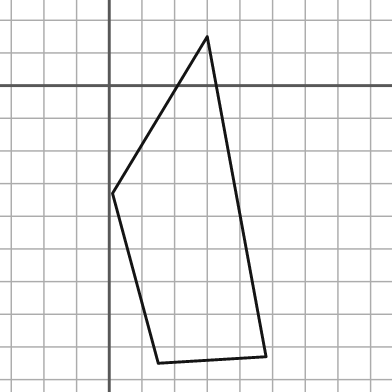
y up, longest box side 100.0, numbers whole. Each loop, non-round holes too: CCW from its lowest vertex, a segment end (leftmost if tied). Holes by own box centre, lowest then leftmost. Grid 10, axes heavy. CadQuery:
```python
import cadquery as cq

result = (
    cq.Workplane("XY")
    .moveTo(15.0, -85.0)
    .lineTo(48.0, -83.0)
    .lineTo(30.0, 15.0)
    .lineTo(1.0, -33.0)
    .close()
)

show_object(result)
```